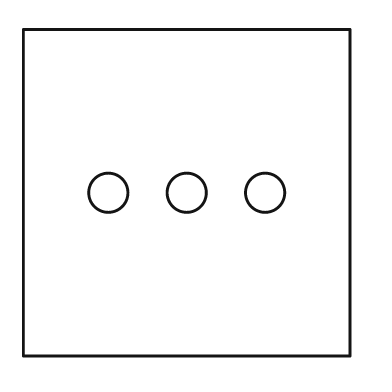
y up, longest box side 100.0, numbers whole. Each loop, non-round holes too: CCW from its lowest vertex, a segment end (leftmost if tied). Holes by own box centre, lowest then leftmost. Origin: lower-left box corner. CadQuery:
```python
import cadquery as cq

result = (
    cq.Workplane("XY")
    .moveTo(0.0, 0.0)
    .lineTo(100.0, 0.0)
    .lineTo(100.0, 100.0)
    .lineTo(0.0, 100.0)
    .close()
    .moveTo(26.0, 50.0)
    .circle(6.0)
    .moveTo(50.0, 50.0)
    .circle(6.0)
    .moveTo(74.0, 50.0)
    .circle(6.0)
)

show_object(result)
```